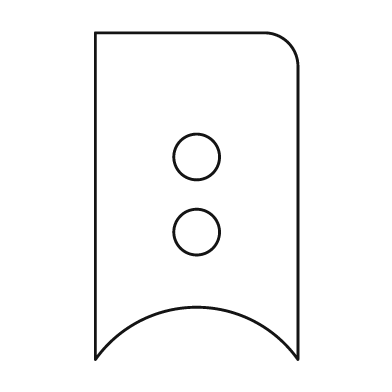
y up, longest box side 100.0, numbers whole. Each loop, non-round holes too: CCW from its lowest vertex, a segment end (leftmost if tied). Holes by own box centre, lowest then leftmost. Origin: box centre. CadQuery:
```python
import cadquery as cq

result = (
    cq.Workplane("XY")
    .moveTo(-31.0, -50.0)
    .threePointArc((0.0, -34.0), (31.0, -50.0))
    .lineTo(31.0, 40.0)
    .threePointArc((28.0, 47.0), (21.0, 50.0))
    .lineTo(-31.0, 50.0)
    .close()
    .moveTo(0.0, -11.0)
    .circle(7.0)
    .moveTo(0.0, 12.0)
    .circle(7.0)
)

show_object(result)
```